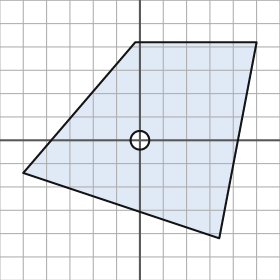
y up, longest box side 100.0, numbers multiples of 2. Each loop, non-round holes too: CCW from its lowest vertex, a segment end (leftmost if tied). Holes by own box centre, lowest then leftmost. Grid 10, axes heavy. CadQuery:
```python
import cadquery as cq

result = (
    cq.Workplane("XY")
    .moveTo(34.0, -42.0)
    .lineTo(50.0, 42.0)
    .lineTo(-2.0, 42.0)
    .lineTo(-50.0, -14.0)
    .close()
    .moveTo(0.0, 0.0)
    .circle(4.0)
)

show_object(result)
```